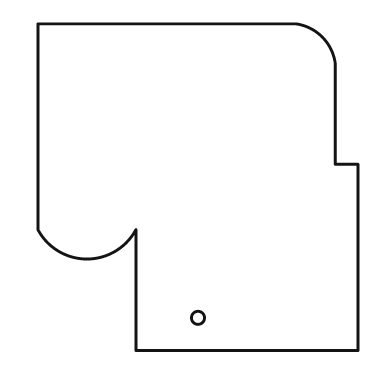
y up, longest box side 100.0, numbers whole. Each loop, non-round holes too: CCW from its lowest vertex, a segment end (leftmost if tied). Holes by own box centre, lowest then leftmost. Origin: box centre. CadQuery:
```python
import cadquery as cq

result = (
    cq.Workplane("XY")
    .moveTo(-19.0, -50.0)
    .lineTo(49.0, -50.0)
    .lineTo(49.0, 7.0)
    .lineTo(42.0, 7.0)
    .lineTo(42.0, 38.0)
    .threePointArc((38.0, 46.0), (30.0, 50.0))
    .lineTo(-49.0, 50.0)
    .lineTo(-49.0, -13.0)
    .threePointArc((-34.0, -22.0), (-19.0, -13.0))
    .close()
    .moveTo(0.0, -40.0)
    .circle(2.0)
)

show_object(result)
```